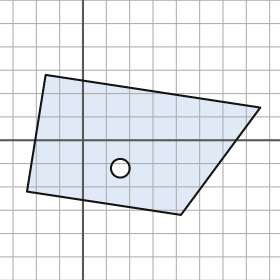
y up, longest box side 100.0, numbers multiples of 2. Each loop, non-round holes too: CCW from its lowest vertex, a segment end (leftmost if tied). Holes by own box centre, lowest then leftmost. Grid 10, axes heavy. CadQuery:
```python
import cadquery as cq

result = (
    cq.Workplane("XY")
    .moveTo(42.0, -32.0)
    .lineTo(76.0, 14.0)
    .lineTo(-16.0, 28.0)
    .lineTo(-24.0, -22.0)
    .close()
    .moveTo(16.0, -12.0)
    .circle(4.0)
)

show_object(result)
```